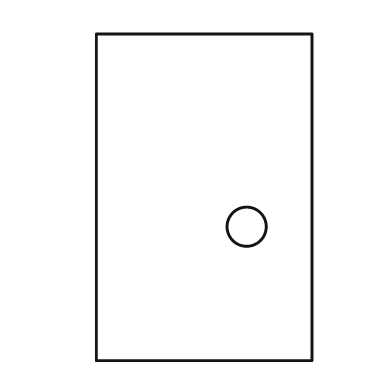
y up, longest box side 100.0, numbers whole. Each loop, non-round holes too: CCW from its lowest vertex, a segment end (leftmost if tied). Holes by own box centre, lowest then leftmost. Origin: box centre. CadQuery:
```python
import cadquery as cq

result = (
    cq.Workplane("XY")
    .moveTo(-33.0, -50.0)
    .lineTo(33.0, -50.0)
    .lineTo(33.0, 50.0)
    .lineTo(-33.0, 50.0)
    .close()
    .moveTo(13.0, -9.0)
    .circle(6.0)
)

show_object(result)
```